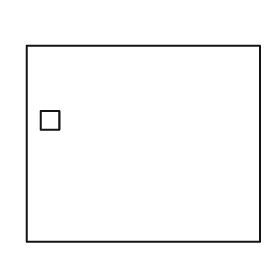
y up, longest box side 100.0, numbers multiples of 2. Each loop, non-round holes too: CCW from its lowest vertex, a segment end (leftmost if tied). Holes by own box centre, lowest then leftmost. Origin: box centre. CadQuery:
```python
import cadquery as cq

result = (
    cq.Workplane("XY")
    .moveTo(-50.0, -42.0)
    .lineTo(50.0, -42.0)
    .lineTo(50.0, 42.0)
    .lineTo(-50.0, 42.0)
    .close()
    .moveTo(-44.0, 6.0)
    .lineTo(-36.0, 6.0)
    .lineTo(-36.0, 14.0)
    .lineTo(-44.0, 14.0)
    .close()
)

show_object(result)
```